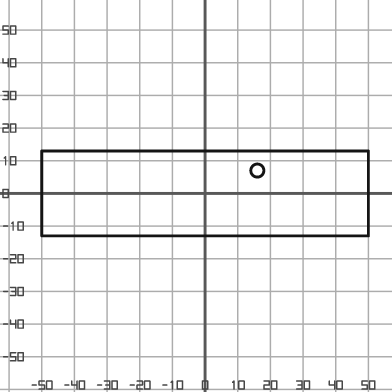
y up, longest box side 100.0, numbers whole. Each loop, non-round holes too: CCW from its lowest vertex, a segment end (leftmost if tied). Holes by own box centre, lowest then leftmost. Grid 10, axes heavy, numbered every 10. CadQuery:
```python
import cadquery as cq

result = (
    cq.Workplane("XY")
    .moveTo(-50.0, -13.0)
    .lineTo(50.0, -13.0)
    .lineTo(50.0, 13.0)
    .lineTo(-50.0, 13.0)
    .close()
    .moveTo(16.0, 7.0)
    .circle(2.0)
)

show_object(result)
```